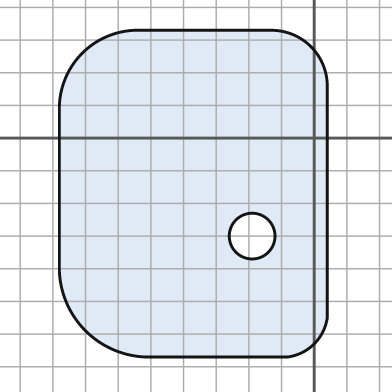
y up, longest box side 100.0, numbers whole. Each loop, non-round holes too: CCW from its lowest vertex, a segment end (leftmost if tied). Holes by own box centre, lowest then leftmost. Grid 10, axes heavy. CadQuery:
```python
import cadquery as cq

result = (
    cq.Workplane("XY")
    .moveTo(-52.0, -67.0)
    .lineTo(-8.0, -67.0)
    .threePointArc((0.0, -63.0), (4.0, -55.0))
    .lineTo(4.0, 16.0)
    .threePointArc((-1.0, 28.0), (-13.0, 33.0))
    .lineTo(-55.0, 33.0)
    .threePointArc((-71.0, 26.0), (-78.0, 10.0))
    .lineTo(-78.0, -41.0)
    .threePointArc((-70.0, -59.0), (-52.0, -67.0))
    .close()
    .moveTo(-19.0, -30.0)
    .circle(7.0)
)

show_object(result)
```